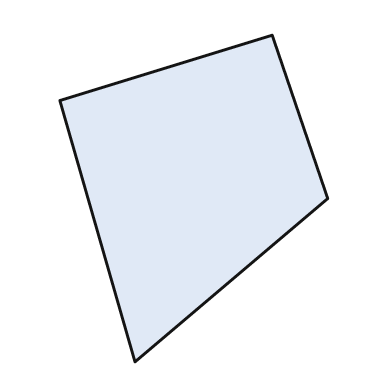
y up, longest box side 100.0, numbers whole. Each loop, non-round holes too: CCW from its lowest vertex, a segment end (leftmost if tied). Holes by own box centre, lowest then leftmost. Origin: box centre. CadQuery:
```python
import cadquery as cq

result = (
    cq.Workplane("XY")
    .moveTo(-18.0, -50.0)
    .lineTo(41.0, 0.0)
    .lineTo(24.0, 50.0)
    .lineTo(-41.0, 30.0)
    .close()
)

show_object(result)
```